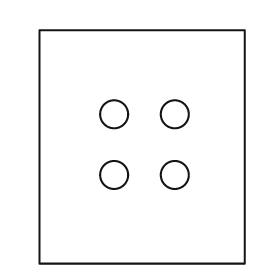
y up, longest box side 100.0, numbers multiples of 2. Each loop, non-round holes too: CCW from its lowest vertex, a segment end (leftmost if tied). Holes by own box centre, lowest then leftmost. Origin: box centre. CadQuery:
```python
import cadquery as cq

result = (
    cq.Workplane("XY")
    .moveTo(-44.0, -50.0)
    .lineTo(44.0, -50.0)
    .lineTo(44.0, 50.0)
    .lineTo(-44.0, 50.0)
    .close()
    .moveTo(-12.0, -12.0)
    .circle(6.0)
    .moveTo(14.0, -12.0)
    .circle(6.0)
    .moveTo(-12.0, 14.0)
    .circle(6.0)
    .moveTo(14.0, 14.0)
    .circle(6.0)
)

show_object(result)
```